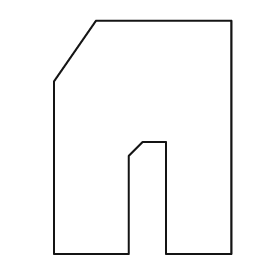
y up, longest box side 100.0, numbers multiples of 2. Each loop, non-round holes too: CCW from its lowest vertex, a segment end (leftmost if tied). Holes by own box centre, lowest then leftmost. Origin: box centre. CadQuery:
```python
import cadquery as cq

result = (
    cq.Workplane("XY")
    .moveTo(-38.0, -50.0)
    .lineTo(-6.0, -50.0)
    .lineTo(-6.0, -8.0)
    .lineTo(0.0, -2.0)
    .lineTo(10.0, -2.0)
    .lineTo(10.0, -50.0)
    .lineTo(38.0, -50.0)
    .lineTo(38.0, 50.0)
    .lineTo(-20.0, 50.0)
    .lineTo(-38.0, 24.0)
    .close()
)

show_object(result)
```